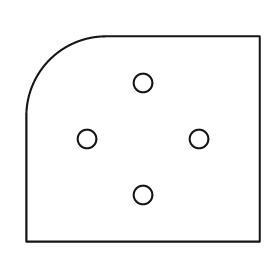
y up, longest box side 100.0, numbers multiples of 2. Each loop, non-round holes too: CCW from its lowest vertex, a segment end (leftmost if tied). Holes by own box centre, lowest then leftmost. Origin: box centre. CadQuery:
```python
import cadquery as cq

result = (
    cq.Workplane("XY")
    .moveTo(-50.0, -44.0)
    .lineTo(50.0, -44.0)
    .lineTo(50.0, 44.0)
    .lineTo(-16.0, 44.0)
    .threePointArc((-40.0, 34.0), (-50.0, 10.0))
    .close()
    .moveTo(0.0, -24.0)
    .circle(4.0)
    .moveTo(-24.0, 0.0)
    .circle(4.0)
    .moveTo(24.0, 0.0)
    .circle(4.0)
    .moveTo(0.0, 24.0)
    .circle(4.0)
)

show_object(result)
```